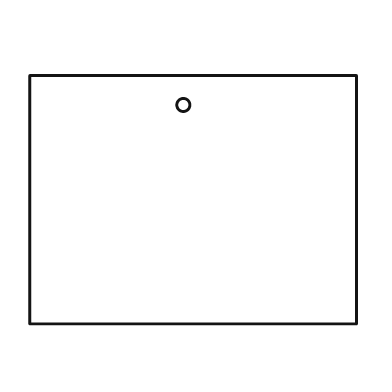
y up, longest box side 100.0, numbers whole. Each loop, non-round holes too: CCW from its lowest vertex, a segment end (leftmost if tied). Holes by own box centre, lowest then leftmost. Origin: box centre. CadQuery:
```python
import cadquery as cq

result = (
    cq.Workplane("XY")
    .moveTo(-50.0, -38.0)
    .lineTo(50.0, -38.0)
    .lineTo(50.0, 38.0)
    .lineTo(-50.0, 38.0)
    .close()
    .moveTo(-3.0, 29.0)
    .circle(2.0)
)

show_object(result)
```